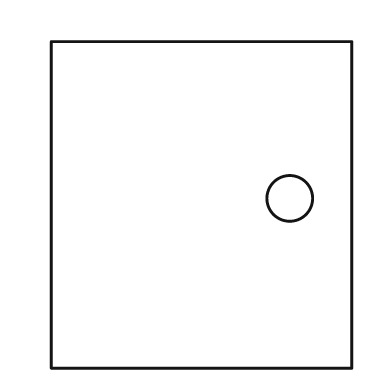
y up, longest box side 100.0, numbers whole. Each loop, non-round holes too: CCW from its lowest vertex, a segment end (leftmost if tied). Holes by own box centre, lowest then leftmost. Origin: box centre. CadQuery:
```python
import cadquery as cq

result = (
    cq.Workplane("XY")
    .moveTo(-46.0, -50.0)
    .lineTo(46.0, -50.0)
    .lineTo(46.0, 50.0)
    .lineTo(-46.0, 50.0)
    .close()
    .moveTo(27.0, 2.0)
    .circle(7.0)
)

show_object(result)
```